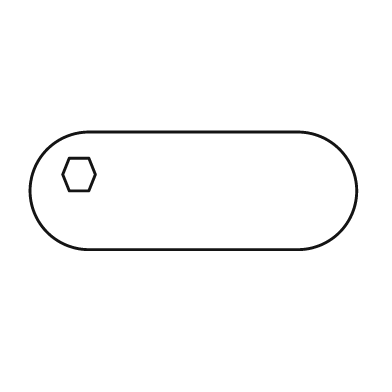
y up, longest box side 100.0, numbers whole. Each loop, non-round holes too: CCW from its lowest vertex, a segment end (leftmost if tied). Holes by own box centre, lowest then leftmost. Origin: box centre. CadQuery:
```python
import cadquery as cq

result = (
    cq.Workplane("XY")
    .moveTo(-32.0, -18.0)
    .lineTo(32.0, -18.0)
    .threePointArc((50.0, 0.0), (32.0, 18.0))
    .lineTo(-32.0, 18.0)
    .threePointArc((-50.0, 0.0), (-32.0, -18.0))
    .close()
    .moveTo(-38.0, 0.0)
    .lineTo(-32.0, 0.0)
    .lineTo(-30.0, 5.0)
    .lineTo(-32.0, 10.0)
    .lineTo(-38.0, 10.0)
    .lineTo(-40.0, 5.0)
    .close()
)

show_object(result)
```